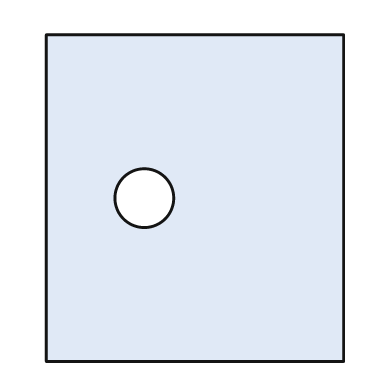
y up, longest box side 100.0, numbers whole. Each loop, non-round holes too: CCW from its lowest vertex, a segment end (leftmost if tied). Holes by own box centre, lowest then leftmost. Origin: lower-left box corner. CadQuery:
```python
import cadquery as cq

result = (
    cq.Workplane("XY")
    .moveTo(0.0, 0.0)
    .lineTo(91.0, 0.0)
    .lineTo(91.0, 100.0)
    .lineTo(0.0, 100.0)
    .close()
    .moveTo(30.0, 50.0)
    .circle(9.0)
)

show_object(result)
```